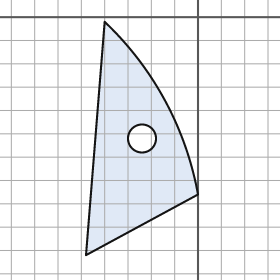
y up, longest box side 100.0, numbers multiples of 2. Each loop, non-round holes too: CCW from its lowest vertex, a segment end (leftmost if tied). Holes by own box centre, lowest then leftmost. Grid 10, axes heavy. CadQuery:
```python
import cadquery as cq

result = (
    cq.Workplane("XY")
    .moveTo(-48.0, -102.0)
    .lineTo(0.0, -76.0)
    .threePointArc((-14.0, -36.0), (-40.0, -2.0))
    .close()
    .moveTo(-24.0, -52.0)
    .circle(6.0)
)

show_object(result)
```